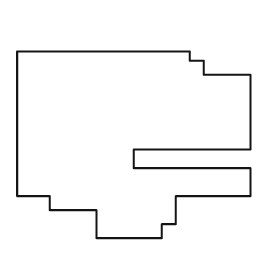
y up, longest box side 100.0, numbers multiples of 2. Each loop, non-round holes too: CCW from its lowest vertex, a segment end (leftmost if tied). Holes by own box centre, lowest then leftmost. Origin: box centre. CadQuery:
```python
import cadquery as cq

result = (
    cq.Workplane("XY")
    .moveTo(-16.0, -40.0)
    .lineTo(12.0, -40.0)
    .lineTo(12.0, -34.0)
    .lineTo(18.0, -34.0)
    .lineTo(18.0, -22.0)
    .lineTo(50.0, -22.0)
    .lineTo(50.0, -10.0)
    .lineTo(0.0, -10.0)
    .lineTo(0.0, -2.0)
    .lineTo(50.0, -2.0)
    .lineTo(50.0, 30.0)
    .lineTo(30.0, 30.0)
    .lineTo(30.0, 36.0)
    .lineTo(24.0, 36.0)
    .lineTo(24.0, 40.0)
    .lineTo(-50.0, 40.0)
    .lineTo(-50.0, -22.0)
    .lineTo(-36.0, -22.0)
    .lineTo(-36.0, -28.0)
    .lineTo(-16.0, -28.0)
    .close()
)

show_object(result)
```